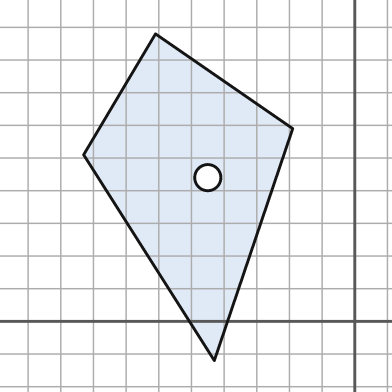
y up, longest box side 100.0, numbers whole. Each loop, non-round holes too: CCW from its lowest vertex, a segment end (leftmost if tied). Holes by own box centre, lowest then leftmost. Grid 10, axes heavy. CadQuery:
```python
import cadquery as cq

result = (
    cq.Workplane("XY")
    .moveTo(-43.0, -12.0)
    .lineTo(-19.0, 59.0)
    .lineTo(-61.0, 88.0)
    .lineTo(-83.0, 51.0)
    .close()
    .moveTo(-45.0, 44.0)
    .circle(4.0)
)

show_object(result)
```